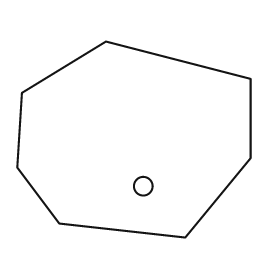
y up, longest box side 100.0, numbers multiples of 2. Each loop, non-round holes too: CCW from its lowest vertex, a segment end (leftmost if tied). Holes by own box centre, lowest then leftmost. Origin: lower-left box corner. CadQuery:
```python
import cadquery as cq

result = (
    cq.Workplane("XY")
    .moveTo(72.0, 0.0)
    .lineTo(100.0, 34.0)
    .lineTo(100.0, 68.0)
    .lineTo(38.0, 84.0)
    .lineTo(2.0, 62.0)
    .lineTo(0.0, 30.0)
    .lineTo(18.0, 6.0)
    .close()
    .moveTo(54.0, 22.0)
    .circle(4.0)
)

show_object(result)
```